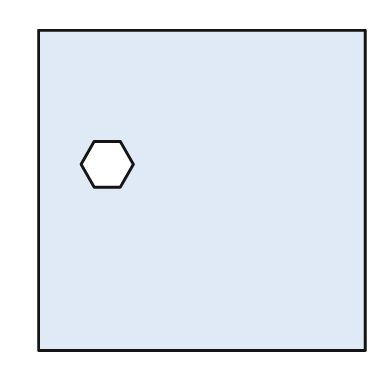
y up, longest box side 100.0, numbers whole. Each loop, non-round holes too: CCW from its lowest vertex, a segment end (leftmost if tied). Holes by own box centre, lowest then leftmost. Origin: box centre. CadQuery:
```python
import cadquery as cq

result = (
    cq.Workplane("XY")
    .moveTo(-50.0, -49.0)
    .lineTo(50.0, -49.0)
    .lineTo(50.0, 49.0)
    .lineTo(-50.0, 49.0)
    .close()
    .moveTo(-33.0, 1.0)
    .lineTo(-25.0, 1.0)
    .lineTo(-21.0, 8.0)
    .lineTo(-25.0, 15.0)
    .lineTo(-33.0, 15.0)
    .lineTo(-37.0, 8.0)
    .close()
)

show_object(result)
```